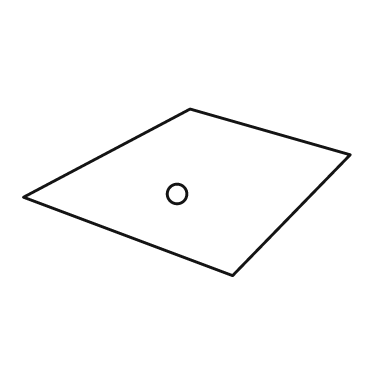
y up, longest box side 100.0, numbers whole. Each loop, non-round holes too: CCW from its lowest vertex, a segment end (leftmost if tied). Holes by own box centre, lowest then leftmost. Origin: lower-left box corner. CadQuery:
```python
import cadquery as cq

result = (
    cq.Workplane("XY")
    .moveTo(64.0, 0.0)
    .lineTo(100.0, 37.0)
    .lineTo(51.0, 51.0)
    .lineTo(0.0, 24.0)
    .close()
    .moveTo(47.0, 25.0)
    .circle(3.0)
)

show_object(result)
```